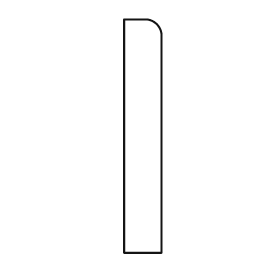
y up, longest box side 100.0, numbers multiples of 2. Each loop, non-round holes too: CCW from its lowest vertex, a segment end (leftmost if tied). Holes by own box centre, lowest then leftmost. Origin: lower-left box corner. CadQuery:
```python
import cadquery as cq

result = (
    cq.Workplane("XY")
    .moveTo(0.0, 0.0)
    .lineTo(16.0, 0.0)
    .lineTo(16.0, 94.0)
    .threePointArc((14.0, 98.0), (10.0, 100.0))
    .lineTo(0.0, 100.0)
    .close()
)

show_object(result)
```